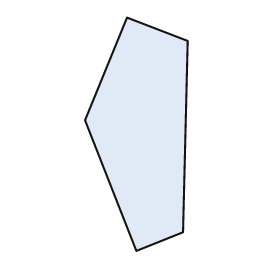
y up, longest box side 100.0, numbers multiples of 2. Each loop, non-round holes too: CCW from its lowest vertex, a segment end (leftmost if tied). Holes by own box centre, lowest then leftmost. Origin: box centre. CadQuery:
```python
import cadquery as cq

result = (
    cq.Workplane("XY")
    .moveTo(0.0, -50.0)
    .lineTo(20.0, -42.0)
    .lineTo(22.0, 40.0)
    .lineTo(-4.0, 50.0)
    .lineTo(-22.0, 6.0)
    .close()
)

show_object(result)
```